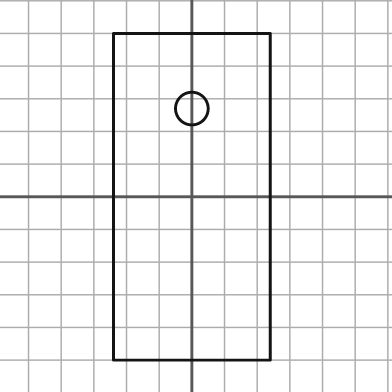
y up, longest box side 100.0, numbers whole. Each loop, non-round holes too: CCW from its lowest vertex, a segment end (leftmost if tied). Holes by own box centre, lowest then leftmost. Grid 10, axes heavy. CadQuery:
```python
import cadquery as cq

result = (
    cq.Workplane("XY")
    .moveTo(-24.0, -50.0)
    .lineTo(24.0, -50.0)
    .lineTo(24.0, 50.0)
    .lineTo(-24.0, 50.0)
    .close()
    .moveTo(0.0, 27.0)
    .circle(5.0)
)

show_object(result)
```